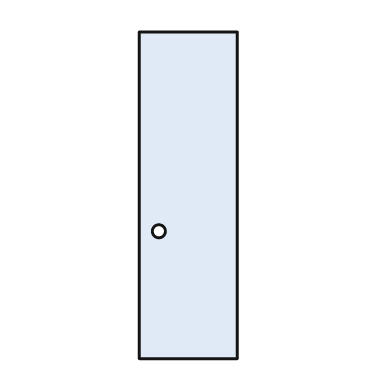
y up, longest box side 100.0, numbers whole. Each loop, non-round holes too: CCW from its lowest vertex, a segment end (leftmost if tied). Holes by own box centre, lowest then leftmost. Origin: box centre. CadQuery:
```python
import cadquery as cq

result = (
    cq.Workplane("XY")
    .moveTo(-15.0, -50.0)
    .lineTo(15.0, -50.0)
    .lineTo(15.0, 50.0)
    .lineTo(-15.0, 50.0)
    .close()
    .moveTo(-9.0, -11.0)
    .circle(2.0)
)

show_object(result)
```